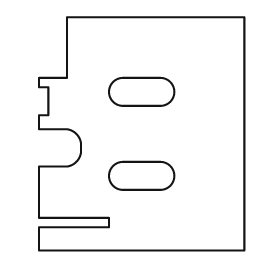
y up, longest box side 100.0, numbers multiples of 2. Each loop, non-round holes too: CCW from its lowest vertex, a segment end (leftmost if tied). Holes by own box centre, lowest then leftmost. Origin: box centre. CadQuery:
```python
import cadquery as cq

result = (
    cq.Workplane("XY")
    .moveTo(-44.0, -50.0)
    .lineTo(44.0, -50.0)
    .lineTo(44.0, 50.0)
    .lineTo(-32.0, 50.0)
    .lineTo(-32.0, 24.0)
    .lineTo(-44.0, 24.0)
    .lineTo(-44.0, 20.0)
    .lineTo(-40.0, 20.0)
    .lineTo(-40.0, 8.0)
    .lineTo(-44.0, 8.0)
    .lineTo(-44.0, 2.0)
    .lineTo(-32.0, 2.0)
    .threePointArc((-28.0, 0.0), (-26.0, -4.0))
    .lineTo(-26.0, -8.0)
    .threePointArc((-28.0, -12.0), (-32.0, -14.0))
    .lineTo(-44.0, -14.0)
    .lineTo(-44.0, -36.0)
    .lineTo(-14.0, -36.0)
    .lineTo(-14.0, -40.0)
    .lineTo(-44.0, -40.0)
    .close()
    .moveTo(-8.0, -24.0)
    .lineTo(8.0, -24.0)
    .threePointArc((14.0, -18.0), (8.0, -12.0))
    .lineTo(-8.0, -12.0)
    .threePointArc((-14.0, -18.0), (-8.0, -24.0))
    .close()
    .moveTo(-8.0, 12.0)
    .lineTo(8.0, 12.0)
    .threePointArc((14.0, 18.0), (8.0, 24.0))
    .lineTo(-8.0, 24.0)
    .threePointArc((-14.0, 18.0), (-8.0, 12.0))
    .close()
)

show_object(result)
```